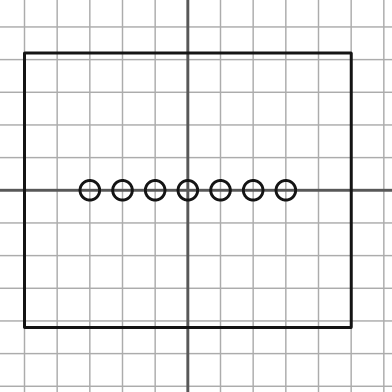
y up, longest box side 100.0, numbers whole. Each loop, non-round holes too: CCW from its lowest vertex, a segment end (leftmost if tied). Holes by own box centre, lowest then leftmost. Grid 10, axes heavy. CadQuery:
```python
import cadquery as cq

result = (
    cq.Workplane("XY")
    .moveTo(-50.0, -42.0)
    .lineTo(50.0, -42.0)
    .lineTo(50.0, 42.0)
    .lineTo(-50.0, 42.0)
    .close()
    .moveTo(-30.0, 0.0)
    .circle(3.0)
    .moveTo(-20.0, 0.0)
    .circle(3.0)
    .moveTo(-10.0, 0.0)
    .circle(3.0)
    .moveTo(0.0, 0.0)
    .circle(3.0)
    .moveTo(10.0, 0.0)
    .circle(3.0)
    .moveTo(20.0, 0.0)
    .circle(3.0)
    .moveTo(30.0, 0.0)
    .circle(3.0)
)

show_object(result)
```